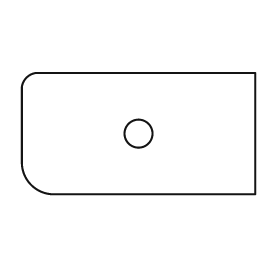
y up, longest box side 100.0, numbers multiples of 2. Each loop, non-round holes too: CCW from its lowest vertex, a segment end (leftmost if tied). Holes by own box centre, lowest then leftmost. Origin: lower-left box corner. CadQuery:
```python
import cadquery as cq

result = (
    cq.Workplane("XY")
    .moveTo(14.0, 0.0)
    .lineTo(100.0, 0.0)
    .lineTo(100.0, 52.0)
    .lineTo(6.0, 52.0)
    .threePointArc((2.0, 50.0), (0.0, 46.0))
    .lineTo(0.0, 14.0)
    .threePointArc((4.0, 4.0), (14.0, 0.0))
    .close()
    .moveTo(50.0, 26.0)
    .circle(6.0)
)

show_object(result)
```